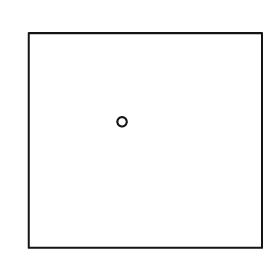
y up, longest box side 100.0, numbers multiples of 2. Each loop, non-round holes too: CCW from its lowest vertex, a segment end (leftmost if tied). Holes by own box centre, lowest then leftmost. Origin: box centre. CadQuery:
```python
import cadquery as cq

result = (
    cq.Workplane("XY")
    .moveTo(-50.0, -46.0)
    .lineTo(50.0, -46.0)
    .lineTo(50.0, 46.0)
    .lineTo(-50.0, 46.0)
    .close()
    .moveTo(-10.0, 8.0)
    .circle(2.0)
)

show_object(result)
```